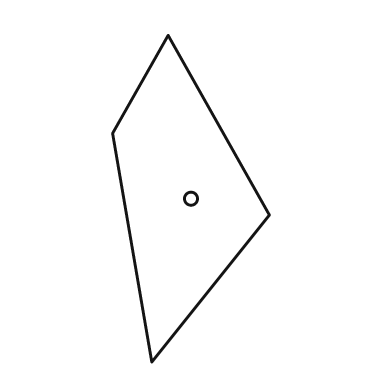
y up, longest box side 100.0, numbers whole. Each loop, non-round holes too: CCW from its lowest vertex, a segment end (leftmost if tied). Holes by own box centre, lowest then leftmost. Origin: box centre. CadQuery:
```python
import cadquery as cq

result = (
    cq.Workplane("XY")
    .moveTo(-12.0, -50.0)
    .lineTo(24.0, -5.0)
    .lineTo(-7.0, 50.0)
    .lineTo(-24.0, 20.0)
    .close()
    .moveTo(0.0, 0.0)
    .circle(2.0)
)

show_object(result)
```